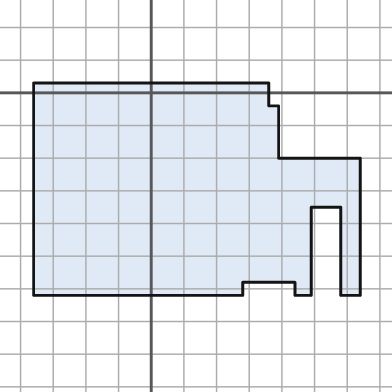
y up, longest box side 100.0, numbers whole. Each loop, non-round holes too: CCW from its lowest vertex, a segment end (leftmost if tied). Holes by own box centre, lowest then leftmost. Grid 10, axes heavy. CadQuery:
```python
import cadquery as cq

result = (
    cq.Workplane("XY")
    .moveTo(-36.0, -62.0)
    .lineTo(28.0, -62.0)
    .lineTo(28.0, -58.0)
    .lineTo(44.0, -58.0)
    .lineTo(44.0, -62.0)
    .lineTo(49.0, -62.0)
    .lineTo(49.0, -35.0)
    .lineTo(58.0, -35.0)
    .lineTo(58.0, -62.0)
    .lineTo(64.0, -62.0)
    .lineTo(64.0, -20.0)
    .lineTo(39.0, -20.0)
    .lineTo(39.0, -4.0)
    .lineTo(36.0, -4.0)
    .lineTo(36.0, 3.0)
    .lineTo(-36.0, 3.0)
    .close()
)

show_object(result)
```